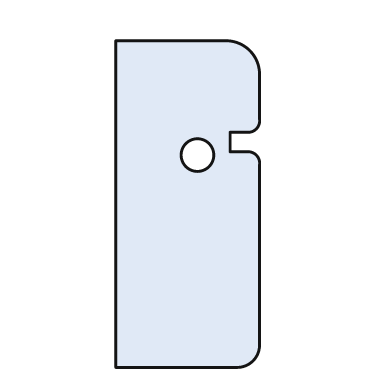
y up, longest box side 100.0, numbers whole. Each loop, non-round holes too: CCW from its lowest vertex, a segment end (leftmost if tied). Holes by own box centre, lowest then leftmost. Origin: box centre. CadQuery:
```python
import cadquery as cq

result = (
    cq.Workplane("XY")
    .moveTo(-22.0, -50.0)
    .lineTo(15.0, -50.0)
    .threePointArc((20.0, -48.0), (22.0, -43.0))
    .lineTo(22.0, 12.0)
    .threePointArc((21.0, 15.0), (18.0, 16.0))
    .lineTo(13.0, 16.0)
    .lineTo(13.0, 22.0)
    .lineTo(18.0, 22.0)
    .threePointArc((21.0, 23.0), (22.0, 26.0))
    .lineTo(22.0, 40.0)
    .threePointArc((19.0, 47.0), (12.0, 50.0))
    .lineTo(-22.0, 50.0)
    .close()
    .moveTo(3.0, 15.0)
    .circle(5.0)
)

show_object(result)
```